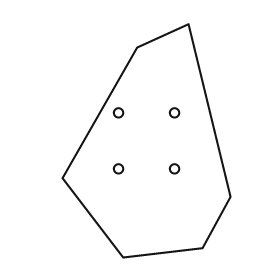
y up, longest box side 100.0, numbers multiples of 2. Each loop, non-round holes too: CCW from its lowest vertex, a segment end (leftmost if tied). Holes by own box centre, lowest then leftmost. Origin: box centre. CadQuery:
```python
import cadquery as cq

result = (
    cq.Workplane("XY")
    .moveTo(-10.0, -50.0)
    .lineTo(24.0, -46.0)
    .lineTo(36.0, -24.0)
    .lineTo(18.0, 50.0)
    .lineTo(-4.0, 40.0)
    .lineTo(-36.0, -16.0)
    .close()
    .moveTo(-12.0, -12.0)
    .circle(2.0)
    .moveTo(12.0, -12.0)
    .circle(2.0)
    .moveTo(-12.0, 12.0)
    .circle(2.0)
    .moveTo(12.0, 12.0)
    .circle(2.0)
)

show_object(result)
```